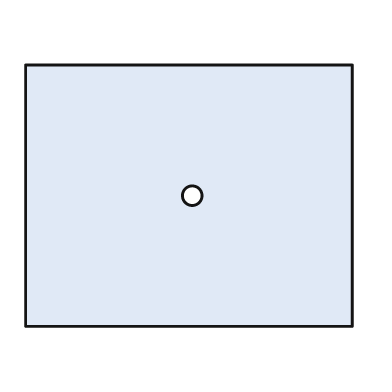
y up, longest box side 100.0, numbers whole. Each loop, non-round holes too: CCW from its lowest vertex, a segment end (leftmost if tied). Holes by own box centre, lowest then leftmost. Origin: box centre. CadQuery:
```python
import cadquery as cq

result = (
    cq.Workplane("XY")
    .moveTo(-50.0, -40.0)
    .lineTo(50.0, -40.0)
    .lineTo(50.0, 40.0)
    .lineTo(-50.0, 40.0)
    .close()
    .moveTo(1.0, 0.0)
    .circle(3.0)
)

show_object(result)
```